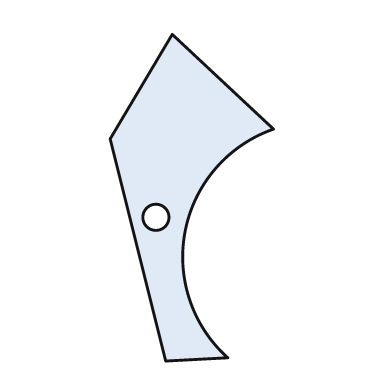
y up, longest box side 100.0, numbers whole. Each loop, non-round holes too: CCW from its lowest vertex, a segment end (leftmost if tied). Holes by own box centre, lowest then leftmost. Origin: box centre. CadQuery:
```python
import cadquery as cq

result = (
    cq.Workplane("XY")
    .moveTo(-8.0, -50.0)
    .lineTo(11.0, -49.0)
    .threePointArc((-2.0, -10.0), (25.0, 21.0))
    .lineTo(-6.0, 50.0)
    .lineTo(-25.0, 18.0)
    .close()
    .moveTo(-11.0, -6.0)
    .circle(4.0)
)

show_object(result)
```